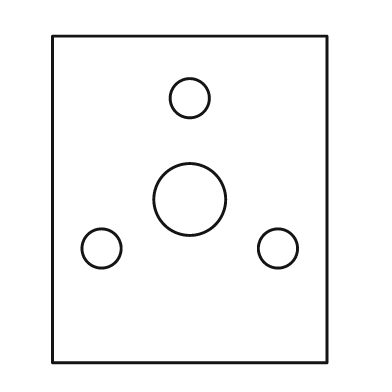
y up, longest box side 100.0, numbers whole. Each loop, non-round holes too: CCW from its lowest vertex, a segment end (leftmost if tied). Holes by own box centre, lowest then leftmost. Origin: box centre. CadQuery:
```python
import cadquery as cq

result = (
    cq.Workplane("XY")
    .moveTo(-42.0, -50.0)
    .lineTo(42.0, -50.0)
    .lineTo(42.0, 50.0)
    .lineTo(-42.0, 50.0)
    .close()
    .moveTo(-27.0, -15.0)
    .circle(6.0)
    .moveTo(27.0, -15.0)
    .circle(6.0)
    .moveTo(0.0, 0.0)
    .circle(11.0)
    .moveTo(0.0, 31.0)
    .circle(6.0)
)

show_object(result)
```